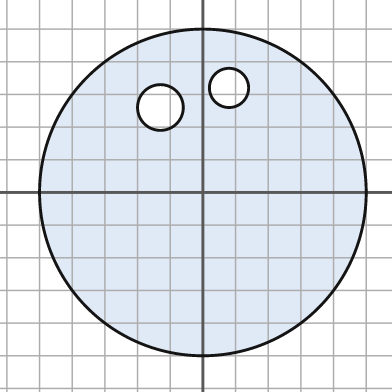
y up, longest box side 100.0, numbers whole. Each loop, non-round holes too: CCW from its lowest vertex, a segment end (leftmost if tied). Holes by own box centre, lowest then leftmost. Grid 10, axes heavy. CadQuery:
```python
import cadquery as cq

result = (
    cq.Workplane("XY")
    .moveTo(0.0, 0.0)
    .circle(50.0)
    .moveTo(-13.0, 26.0)
    .circle(7.0)
    .moveTo(8.0, 32.0)
    .circle(6.0)
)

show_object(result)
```